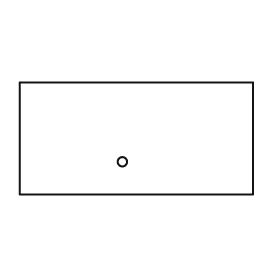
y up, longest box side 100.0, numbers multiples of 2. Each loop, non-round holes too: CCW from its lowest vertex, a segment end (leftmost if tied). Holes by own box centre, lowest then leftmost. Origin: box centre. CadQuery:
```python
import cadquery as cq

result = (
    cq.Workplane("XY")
    .moveTo(-50.0, -24.0)
    .lineTo(50.0, -24.0)
    .lineTo(50.0, 24.0)
    .lineTo(-50.0, 24.0)
    .close()
    .moveTo(-6.0, -10.0)
    .circle(2.0)
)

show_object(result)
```